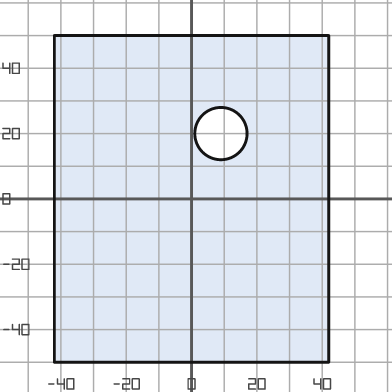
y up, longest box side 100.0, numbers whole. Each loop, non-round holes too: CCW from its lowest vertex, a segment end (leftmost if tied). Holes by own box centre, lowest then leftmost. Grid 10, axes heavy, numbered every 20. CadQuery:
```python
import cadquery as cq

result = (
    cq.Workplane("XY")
    .moveTo(-42.0, -50.0)
    .lineTo(42.0, -50.0)
    .lineTo(42.0, 50.0)
    .lineTo(-42.0, 50.0)
    .close()
    .moveTo(9.0, 20.0)
    .circle(8.0)
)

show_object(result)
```